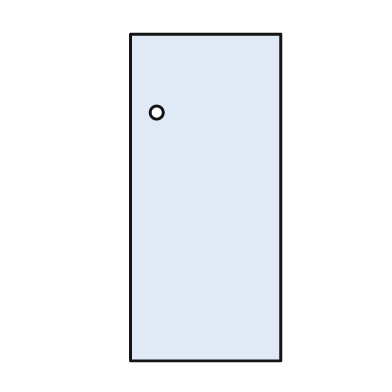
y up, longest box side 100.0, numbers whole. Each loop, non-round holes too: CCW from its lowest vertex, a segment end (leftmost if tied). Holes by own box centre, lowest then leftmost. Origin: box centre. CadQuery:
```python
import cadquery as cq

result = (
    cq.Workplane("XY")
    .moveTo(-23.0, -50.0)
    .lineTo(23.0, -50.0)
    .lineTo(23.0, 50.0)
    .lineTo(-23.0, 50.0)
    .close()
    .moveTo(-15.0, 26.0)
    .circle(2.0)
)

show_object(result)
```